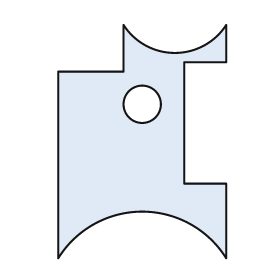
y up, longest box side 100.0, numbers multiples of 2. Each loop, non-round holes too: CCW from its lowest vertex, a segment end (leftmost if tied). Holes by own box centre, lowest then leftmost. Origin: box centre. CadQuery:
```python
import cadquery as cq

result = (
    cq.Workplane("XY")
    .moveTo(-36.0, -50.0)
    .threePointArc((0.0, -30.0), (36.0, -50.0))
    .lineTo(36.0, -18.0)
    .lineTo(18.0, -18.0)
    .lineTo(18.0, 34.0)
    .lineTo(36.0, 34.0)
    .lineTo(36.0, 50.0)
    .threePointArc((14.0, 38.0), (-8.0, 50.0))
    .lineTo(-8.0, 30.0)
    .lineTo(-36.0, 30.0)
    .close()
    .moveTo(0.0, 16.0)
    .circle(8.0)
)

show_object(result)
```